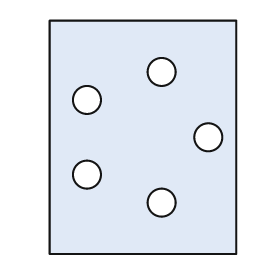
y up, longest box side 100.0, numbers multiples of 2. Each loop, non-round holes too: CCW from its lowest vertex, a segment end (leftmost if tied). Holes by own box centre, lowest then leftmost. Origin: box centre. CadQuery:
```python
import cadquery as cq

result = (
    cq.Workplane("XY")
    .moveTo(-40.0, -50.0)
    .lineTo(40.0, -50.0)
    .lineTo(40.0, 50.0)
    .lineTo(-40.0, 50.0)
    .close()
    .moveTo(8.0, -28.0)
    .circle(6.0)
    .moveTo(-24.0, -16.0)
    .circle(6.0)
    .moveTo(28.0, 0.0)
    .circle(6.0)
    .moveTo(-24.0, 16.0)
    .circle(6.0)
    .moveTo(8.0, 28.0)
    .circle(6.0)
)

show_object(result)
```